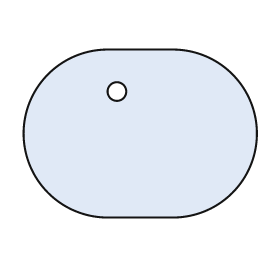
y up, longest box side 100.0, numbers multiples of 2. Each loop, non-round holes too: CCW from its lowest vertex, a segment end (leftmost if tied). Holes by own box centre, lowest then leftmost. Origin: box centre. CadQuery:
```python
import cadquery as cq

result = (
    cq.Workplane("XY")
    .moveTo(-14.0, -36.0)
    .lineTo(14.0, -36.0)
    .threePointArc((50.0, 0.0), (14.0, 36.0))
    .lineTo(-14.0, 36.0)
    .threePointArc((-50.0, 0.0), (-14.0, -36.0))
    .close()
    .moveTo(-10.0, 18.0)
    .circle(4.0)
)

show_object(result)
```